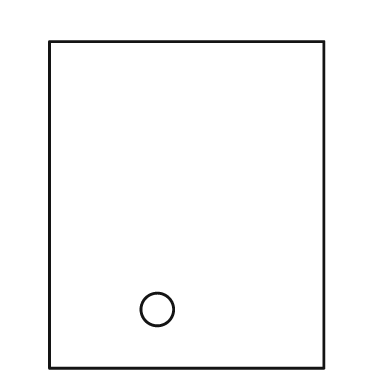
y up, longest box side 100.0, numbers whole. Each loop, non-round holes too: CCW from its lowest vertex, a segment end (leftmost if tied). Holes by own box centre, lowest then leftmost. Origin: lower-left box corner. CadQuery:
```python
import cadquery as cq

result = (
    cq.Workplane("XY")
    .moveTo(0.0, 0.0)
    .lineTo(84.0, 0.0)
    .lineTo(84.0, 100.0)
    .lineTo(0.0, 100.0)
    .close()
    .moveTo(33.0, 18.0)
    .circle(5.0)
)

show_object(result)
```